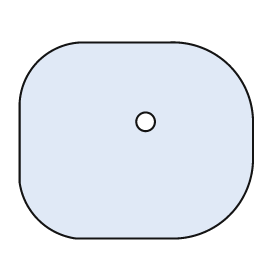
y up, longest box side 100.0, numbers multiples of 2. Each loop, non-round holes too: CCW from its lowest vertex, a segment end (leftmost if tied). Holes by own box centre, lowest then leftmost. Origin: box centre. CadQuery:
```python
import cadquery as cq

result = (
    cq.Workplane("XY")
    .moveTo(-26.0, -42.0)
    .lineTo(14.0, -42.0)
    .threePointArc((40.0, -32.0), (50.0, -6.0))
    .lineTo(50.0, 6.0)
    .threePointArc((40.0, 32.0), (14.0, 42.0))
    .lineTo(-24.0, 42.0)
    .threePointArc((-42.0, 34.0), (-50.0, 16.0))
    .lineTo(-50.0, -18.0)
    .threePointArc((-42.0, -34.0), (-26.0, -42.0))
    .close()
    .moveTo(4.0, 8.0)
    .circle(4.0)
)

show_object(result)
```